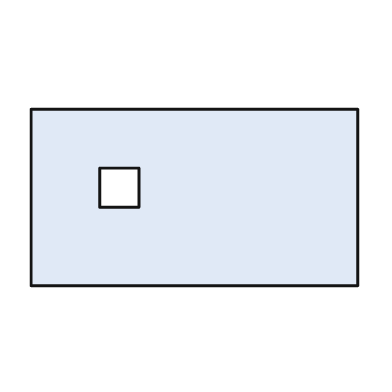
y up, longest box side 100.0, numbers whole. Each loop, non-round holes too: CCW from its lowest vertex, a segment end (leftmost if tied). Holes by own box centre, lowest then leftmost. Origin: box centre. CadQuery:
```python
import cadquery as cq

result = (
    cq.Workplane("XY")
    .moveTo(-50.0, -27.0)
    .lineTo(50.0, -27.0)
    .lineTo(50.0, 27.0)
    .lineTo(-50.0, 27.0)
    .close()
    .moveTo(-29.0, -3.0)
    .lineTo(-17.0, -3.0)
    .lineTo(-17.0, 9.0)
    .lineTo(-29.0, 9.0)
    .close()
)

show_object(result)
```